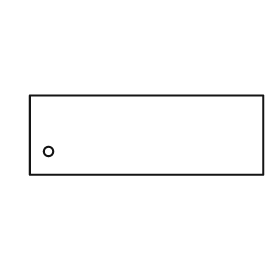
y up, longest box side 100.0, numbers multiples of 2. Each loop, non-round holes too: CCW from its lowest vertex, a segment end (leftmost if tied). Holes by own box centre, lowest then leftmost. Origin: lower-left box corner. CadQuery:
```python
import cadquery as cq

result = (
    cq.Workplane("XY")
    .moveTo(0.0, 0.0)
    .lineTo(100.0, 0.0)
    .lineTo(100.0, 34.0)
    .lineTo(0.0, 34.0)
    .close()
    .moveTo(8.0, 10.0)
    .circle(2.0)
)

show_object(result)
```